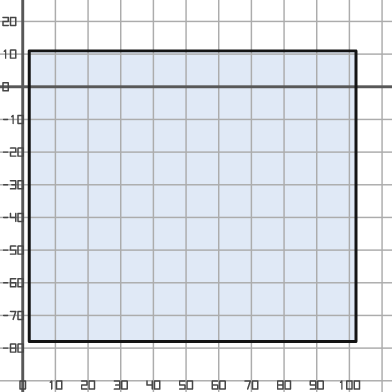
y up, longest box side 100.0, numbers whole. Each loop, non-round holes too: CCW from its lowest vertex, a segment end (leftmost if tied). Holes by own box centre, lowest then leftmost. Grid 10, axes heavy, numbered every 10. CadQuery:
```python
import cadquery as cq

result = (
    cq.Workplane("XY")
    .moveTo(2.0, -78.0)
    .lineTo(102.0, -78.0)
    .lineTo(102.0, 11.0)
    .lineTo(2.0, 11.0)
    .close()
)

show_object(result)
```